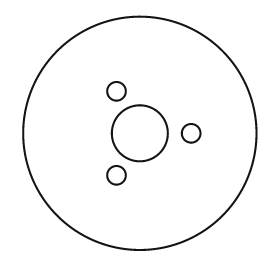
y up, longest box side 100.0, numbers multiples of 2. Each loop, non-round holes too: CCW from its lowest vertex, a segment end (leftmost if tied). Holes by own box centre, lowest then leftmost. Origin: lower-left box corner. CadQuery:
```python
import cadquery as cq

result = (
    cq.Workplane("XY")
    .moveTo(50.0, 50.0)
    .circle(50.0)
    .moveTo(40.0, 32.0)
    .circle(4.0)
    .moveTo(50.0, 50.0)
    .circle(12.0)
    .moveTo(72.0, 50.0)
    .circle(4.0)
    .moveTo(40.0, 68.0)
    .circle(4.0)
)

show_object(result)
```